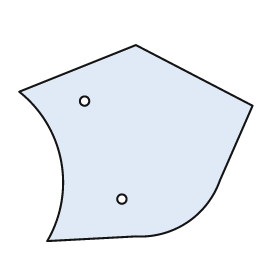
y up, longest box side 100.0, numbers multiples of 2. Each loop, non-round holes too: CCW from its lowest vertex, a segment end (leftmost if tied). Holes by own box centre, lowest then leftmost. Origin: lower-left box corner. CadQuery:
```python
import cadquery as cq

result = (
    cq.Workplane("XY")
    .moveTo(12.0, 0.0)
    .lineTo(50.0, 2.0)
    .threePointArc((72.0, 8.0), (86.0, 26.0))
    .lineTo(100.0, 58.0)
    .lineTo(50.0, 84.0)
    .lineTo(0.0, 64.0)
    .threePointArc((18.0, 34.0), (12.0, 0.0))
    .close()
    .moveTo(44.0, 18.0)
    .circle(2.0)
    .moveTo(28.0, 60.0)
    .circle(2.0)
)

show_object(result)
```